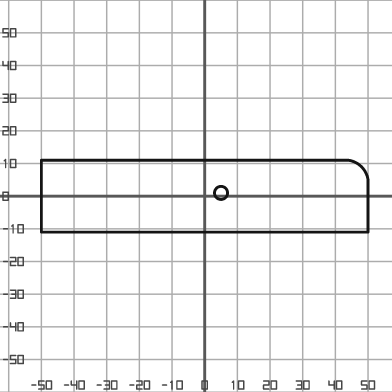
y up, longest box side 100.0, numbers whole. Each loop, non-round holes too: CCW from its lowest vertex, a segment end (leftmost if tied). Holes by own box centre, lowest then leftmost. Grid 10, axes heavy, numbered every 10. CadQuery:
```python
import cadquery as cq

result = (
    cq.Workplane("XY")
    .moveTo(-50.0, -11.0)
    .lineTo(50.0, -11.0)
    .lineTo(50.0, 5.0)
    .threePointArc((48.0, 9.0), (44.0, 11.0))
    .lineTo(-50.0, 11.0)
    .close()
    .moveTo(5.0, 1.0)
    .circle(2.0)
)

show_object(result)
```